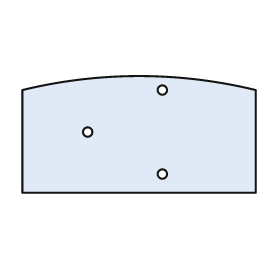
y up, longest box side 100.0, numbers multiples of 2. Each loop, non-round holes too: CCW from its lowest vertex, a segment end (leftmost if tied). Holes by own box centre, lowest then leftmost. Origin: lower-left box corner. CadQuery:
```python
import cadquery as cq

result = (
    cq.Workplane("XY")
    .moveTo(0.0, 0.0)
    .lineTo(100.0, 0.0)
    .lineTo(100.0, 44.0)
    .threePointArc((50.0, 50.0), (0.0, 44.0))
    .close()
    .moveTo(60.0, 8.0)
    .circle(2.0)
    .moveTo(28.0, 26.0)
    .circle(2.0)
    .moveTo(60.0, 44.0)
    .circle(2.0)
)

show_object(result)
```